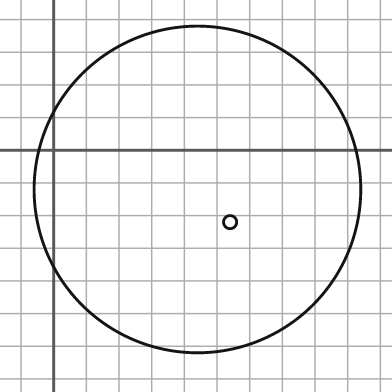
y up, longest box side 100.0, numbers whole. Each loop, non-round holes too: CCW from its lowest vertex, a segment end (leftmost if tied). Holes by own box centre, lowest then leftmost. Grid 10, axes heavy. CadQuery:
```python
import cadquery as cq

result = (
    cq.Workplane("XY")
    .moveTo(44.0, -12.0)
    .circle(50.0)
    .moveTo(54.0, -22.0)
    .circle(2.0)
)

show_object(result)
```